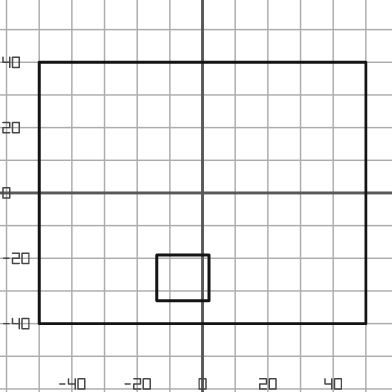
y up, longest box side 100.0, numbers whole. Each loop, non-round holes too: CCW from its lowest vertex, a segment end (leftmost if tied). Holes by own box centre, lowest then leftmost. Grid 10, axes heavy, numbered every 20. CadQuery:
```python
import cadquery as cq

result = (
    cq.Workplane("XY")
    .moveTo(-50.0, -40.0)
    .lineTo(50.0, -40.0)
    .lineTo(50.0, 40.0)
    .lineTo(-50.0, 40.0)
    .close()
    .moveTo(-14.0, -33.0)
    .lineTo(2.0, -33.0)
    .lineTo(2.0, -19.0)
    .lineTo(-14.0, -19.0)
    .close()
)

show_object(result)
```